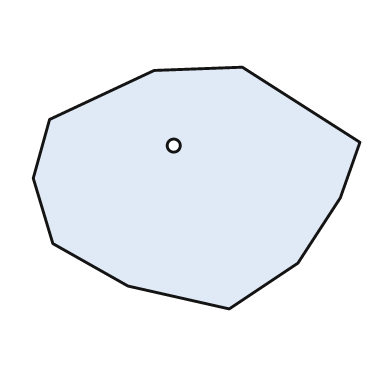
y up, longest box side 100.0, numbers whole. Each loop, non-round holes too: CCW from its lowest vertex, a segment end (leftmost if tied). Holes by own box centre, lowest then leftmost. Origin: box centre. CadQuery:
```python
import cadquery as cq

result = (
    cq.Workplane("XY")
    .moveTo(10.0, -37.0)
    .lineTo(31.0, -23.0)
    .lineTo(44.0, -3.0)
    .lineTo(50.0, 14.0)
    .lineTo(14.0, 37.0)
    .lineTo(-13.0, 36.0)
    .lineTo(-45.0, 21.0)
    .lineTo(-50.0, 3.0)
    .lineTo(-44.0, -17.0)
    .lineTo(-21.0, -30.0)
    .close()
    .moveTo(-7.0, 13.0)
    .circle(2.0)
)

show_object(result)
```